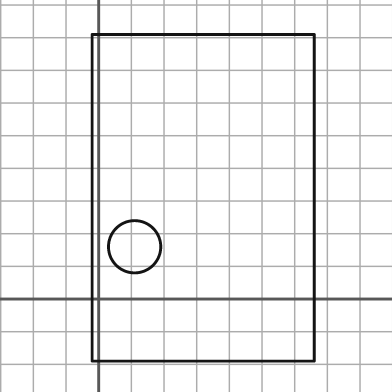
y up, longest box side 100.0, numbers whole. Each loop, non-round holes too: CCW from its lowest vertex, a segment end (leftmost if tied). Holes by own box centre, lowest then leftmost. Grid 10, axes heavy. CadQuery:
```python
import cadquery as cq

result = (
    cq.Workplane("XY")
    .moveTo(-2.0, -19.0)
    .lineTo(66.0, -19.0)
    .lineTo(66.0, 81.0)
    .lineTo(-2.0, 81.0)
    .close()
    .moveTo(11.0, 16.0)
    .circle(8.0)
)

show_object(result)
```